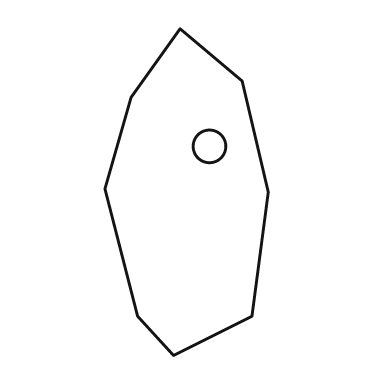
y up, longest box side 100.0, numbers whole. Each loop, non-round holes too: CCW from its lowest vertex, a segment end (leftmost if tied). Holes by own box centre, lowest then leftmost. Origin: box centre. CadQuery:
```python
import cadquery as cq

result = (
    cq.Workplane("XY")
    .moveTo(-4.0, -50.0)
    .lineTo(20.0, -38.0)
    .lineTo(25.0, 0.0)
    .lineTo(17.0, 34.0)
    .lineTo(-2.0, 50.0)
    .lineTo(-17.0, 29.0)
    .lineTo(-25.0, 1.0)
    .lineTo(-15.0, -38.0)
    .close()
    .moveTo(7.0, 14.0)
    .circle(5.0)
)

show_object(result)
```